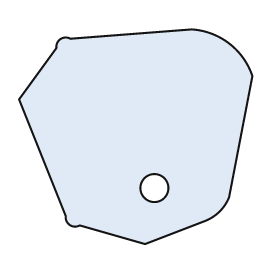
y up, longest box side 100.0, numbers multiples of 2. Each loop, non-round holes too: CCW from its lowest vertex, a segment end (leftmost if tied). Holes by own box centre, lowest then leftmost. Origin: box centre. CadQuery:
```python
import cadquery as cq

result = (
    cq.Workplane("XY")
    .moveTo(4.0, -46.0)
    .lineTo(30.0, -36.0)
    .threePointArc((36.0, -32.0), (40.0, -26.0))
    .lineTo(50.0, 26.0)
    .threePointArc((40.0, 40.0), (24.0, 46.0))
    .lineTo(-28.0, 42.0)
    .threePointArc((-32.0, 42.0), (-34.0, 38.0))
    .lineTo(-50.0, 16.0)
    .lineTo(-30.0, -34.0)
    .threePointArc((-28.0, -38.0), (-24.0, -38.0))
    .close()
    .moveTo(8.0, -22.0)
    .circle(6.0)
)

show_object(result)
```